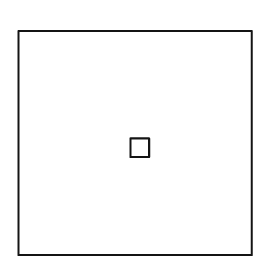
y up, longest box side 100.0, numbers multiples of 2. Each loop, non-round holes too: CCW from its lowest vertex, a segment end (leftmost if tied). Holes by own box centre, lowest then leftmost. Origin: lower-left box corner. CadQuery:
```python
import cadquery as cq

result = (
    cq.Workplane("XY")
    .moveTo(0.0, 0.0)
    .lineTo(100.0, 0.0)
    .lineTo(100.0, 96.0)
    .lineTo(0.0, 96.0)
    .close()
    .moveTo(48.0, 42.0)
    .lineTo(56.0, 42.0)
    .lineTo(56.0, 50.0)
    .lineTo(48.0, 50.0)
    .close()
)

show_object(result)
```